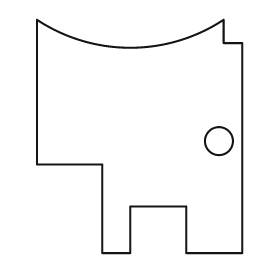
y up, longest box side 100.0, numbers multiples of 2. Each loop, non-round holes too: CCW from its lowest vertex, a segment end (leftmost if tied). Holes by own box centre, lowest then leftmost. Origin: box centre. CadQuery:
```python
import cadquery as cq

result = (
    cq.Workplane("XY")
    .moveTo(-16.0, -50.0)
    .lineTo(-4.0, -50.0)
    .lineTo(-4.0, -30.0)
    .lineTo(20.0, -30.0)
    .lineTo(20.0, -50.0)
    .lineTo(44.0, -50.0)
    .lineTo(44.0, 40.0)
    .lineTo(36.0, 40.0)
    .lineTo(36.0, 50.0)
    .threePointArc((-4.0, 38.0), (-44.0, 50.0))
    .lineTo(-44.0, -12.0)
    .lineTo(-16.0, -12.0)
    .close()
    .moveTo(34.0, -2.0)
    .circle(6.0)
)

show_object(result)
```